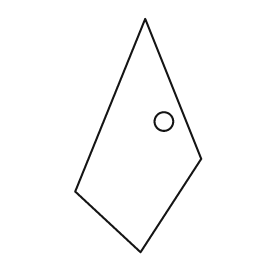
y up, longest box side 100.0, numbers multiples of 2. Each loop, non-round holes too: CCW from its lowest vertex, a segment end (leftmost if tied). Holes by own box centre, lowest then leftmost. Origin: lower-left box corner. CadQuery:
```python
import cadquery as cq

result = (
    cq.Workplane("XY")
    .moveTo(28.0, 0.0)
    .lineTo(54.0, 40.0)
    .lineTo(30.0, 100.0)
    .lineTo(0.0, 26.0)
    .close()
    .moveTo(38.0, 56.0)
    .circle(4.0)
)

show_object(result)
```